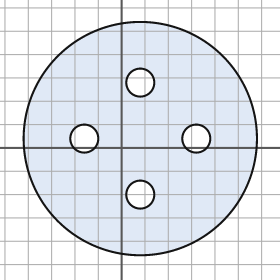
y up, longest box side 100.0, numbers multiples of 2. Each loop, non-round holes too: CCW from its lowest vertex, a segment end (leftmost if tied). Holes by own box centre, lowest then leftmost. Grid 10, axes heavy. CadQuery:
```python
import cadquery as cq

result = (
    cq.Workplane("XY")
    .moveTo(8.0, 4.0)
    .circle(50.0)
    .moveTo(8.0, -20.0)
    .circle(6.0)
    .moveTo(-16.0, 4.0)
    .circle(6.0)
    .moveTo(32.0, 4.0)
    .circle(6.0)
    .moveTo(8.0, 28.0)
    .circle(6.0)
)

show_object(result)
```